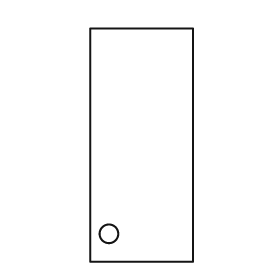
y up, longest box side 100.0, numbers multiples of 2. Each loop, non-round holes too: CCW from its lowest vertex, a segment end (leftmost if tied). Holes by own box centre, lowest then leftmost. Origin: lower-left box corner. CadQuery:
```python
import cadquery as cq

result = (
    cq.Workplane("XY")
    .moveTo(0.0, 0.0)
    .lineTo(44.0, 0.0)
    .lineTo(44.0, 100.0)
    .lineTo(0.0, 100.0)
    .close()
    .moveTo(8.0, 12.0)
    .circle(4.0)
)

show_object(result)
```